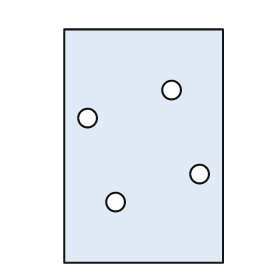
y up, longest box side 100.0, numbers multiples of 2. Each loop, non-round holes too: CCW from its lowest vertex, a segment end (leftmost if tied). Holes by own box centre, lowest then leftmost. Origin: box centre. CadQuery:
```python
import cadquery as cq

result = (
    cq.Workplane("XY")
    .moveTo(-34.0, -50.0)
    .lineTo(34.0, -50.0)
    .lineTo(34.0, 50.0)
    .lineTo(-34.0, 50.0)
    .close()
    .moveTo(-12.0, -24.0)
    .circle(4.0)
    .moveTo(24.0, -12.0)
    .circle(4.0)
    .moveTo(-24.0, 12.0)
    .circle(4.0)
    .moveTo(12.0, 24.0)
    .circle(4.0)
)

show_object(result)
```